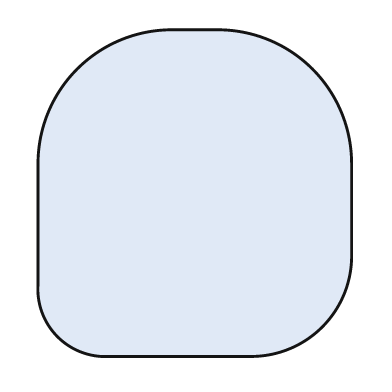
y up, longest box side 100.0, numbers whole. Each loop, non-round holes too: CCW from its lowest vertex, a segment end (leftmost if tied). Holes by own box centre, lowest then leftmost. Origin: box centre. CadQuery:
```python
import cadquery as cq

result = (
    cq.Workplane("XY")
    .moveTo(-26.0, -50.0)
    .lineTo(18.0, -50.0)
    .threePointArc((39.0, -41.0), (48.0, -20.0))
    .lineTo(48.0, 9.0)
    .threePointArc((36.0, 38.0), (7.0, 50.0))
    .lineTo(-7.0, 50.0)
    .threePointArc((-36.0, 38.0), (-48.0, 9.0))
    .lineTo(-48.0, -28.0)
    .threePointArc((-42.0, -44.0), (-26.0, -50.0))
    .close()
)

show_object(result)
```